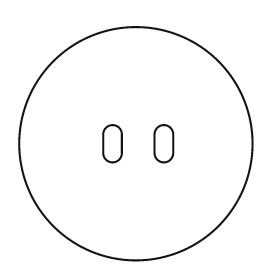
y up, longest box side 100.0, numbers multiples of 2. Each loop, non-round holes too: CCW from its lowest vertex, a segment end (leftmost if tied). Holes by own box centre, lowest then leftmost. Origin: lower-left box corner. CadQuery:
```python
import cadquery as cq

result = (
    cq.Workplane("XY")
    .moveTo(50.0, 50.0)
    .circle(50.0)
    .moveTo(36.0, 46.0)
    .threePointArc((40.0, 42.0), (44.0, 46.0))
    .lineTo(44.0, 54.0)
    .threePointArc((40.0, 58.0), (36.0, 54.0))
    .close()
    .moveTo(58.0, 46.0)
    .threePointArc((62.0, 42.0), (66.0, 46.0))
    .lineTo(66.0, 54.0)
    .threePointArc((62.0, 58.0), (58.0, 54.0))
    .close()
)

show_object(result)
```